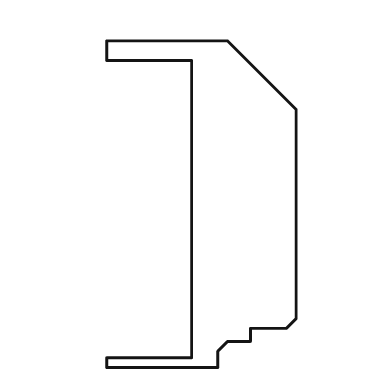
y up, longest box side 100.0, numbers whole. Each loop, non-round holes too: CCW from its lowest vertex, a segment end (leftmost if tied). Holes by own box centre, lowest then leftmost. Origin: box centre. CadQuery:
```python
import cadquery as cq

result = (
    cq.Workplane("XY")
    .moveTo(-29.0, -50.0)
    .lineTo(5.0, -50.0)
    .lineTo(5.0, -45.0)
    .lineTo(8.0, -42.0)
    .lineTo(15.0, -42.0)
    .lineTo(15.0, -38.0)
    .lineTo(26.0, -38.0)
    .lineTo(29.0, -35.0)
    .lineTo(29.0, 29.0)
    .lineTo(8.0, 50.0)
    .lineTo(-29.0, 50.0)
    .lineTo(-29.0, 44.0)
    .lineTo(-3.0, 44.0)
    .lineTo(-3.0, -47.0)
    .lineTo(-29.0, -47.0)
    .close()
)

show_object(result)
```